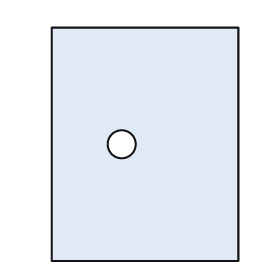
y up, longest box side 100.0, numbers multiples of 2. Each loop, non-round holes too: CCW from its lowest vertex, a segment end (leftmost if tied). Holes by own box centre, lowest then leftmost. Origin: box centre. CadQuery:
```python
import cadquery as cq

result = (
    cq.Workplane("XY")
    .moveTo(-40.0, -50.0)
    .lineTo(40.0, -50.0)
    .lineTo(40.0, 50.0)
    .lineTo(-40.0, 50.0)
    .close()
    .moveTo(-10.0, 0.0)
    .circle(6.0)
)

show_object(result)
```